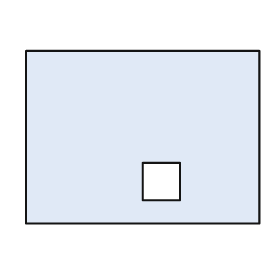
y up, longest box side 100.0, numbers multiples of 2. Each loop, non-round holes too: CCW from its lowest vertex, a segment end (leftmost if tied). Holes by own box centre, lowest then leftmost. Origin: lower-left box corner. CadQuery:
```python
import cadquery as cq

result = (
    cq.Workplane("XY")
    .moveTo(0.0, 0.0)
    .lineTo(100.0, 0.0)
    .lineTo(100.0, 74.0)
    .lineTo(0.0, 74.0)
    .close()
    .moveTo(50.0, 10.0)
    .lineTo(66.0, 10.0)
    .lineTo(66.0, 26.0)
    .lineTo(50.0, 26.0)
    .close()
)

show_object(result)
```